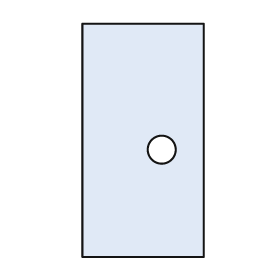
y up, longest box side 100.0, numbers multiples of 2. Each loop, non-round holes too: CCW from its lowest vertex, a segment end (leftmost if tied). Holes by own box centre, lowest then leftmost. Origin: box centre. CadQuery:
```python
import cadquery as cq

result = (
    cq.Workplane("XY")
    .moveTo(-26.0, -50.0)
    .lineTo(26.0, -50.0)
    .lineTo(26.0, 50.0)
    .lineTo(-26.0, 50.0)
    .close()
    .moveTo(8.0, -4.0)
    .circle(6.0)
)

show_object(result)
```